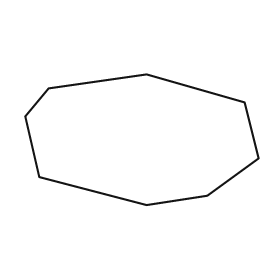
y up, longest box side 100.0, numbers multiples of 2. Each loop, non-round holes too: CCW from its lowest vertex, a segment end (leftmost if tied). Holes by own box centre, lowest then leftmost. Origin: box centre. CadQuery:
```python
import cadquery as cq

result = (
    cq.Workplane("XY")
    .moveTo(2.0, -28.0)
    .lineTo(28.0, -24.0)
    .lineTo(50.0, -8.0)
    .lineTo(44.0, 16.0)
    .lineTo(2.0, 28.0)
    .lineTo(-40.0, 22.0)
    .lineTo(-50.0, 10.0)
    .lineTo(-44.0, -16.0)
    .close()
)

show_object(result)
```